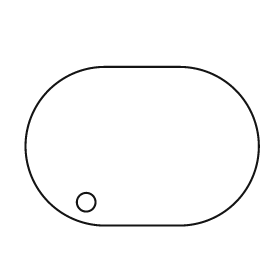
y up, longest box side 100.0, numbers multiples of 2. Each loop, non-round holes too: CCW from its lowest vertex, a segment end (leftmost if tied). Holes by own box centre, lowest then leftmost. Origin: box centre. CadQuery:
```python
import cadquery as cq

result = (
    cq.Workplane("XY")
    .moveTo(-16.0, -34.0)
    .lineTo(16.0, -34.0)
    .threePointArc((50.0, 0.0), (16.0, 34.0))
    .lineTo(-16.0, 34.0)
    .threePointArc((-50.0, 0.0), (-16.0, -34.0))
    .close()
    .moveTo(-24.0, -24.0)
    .circle(4.0)
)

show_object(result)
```